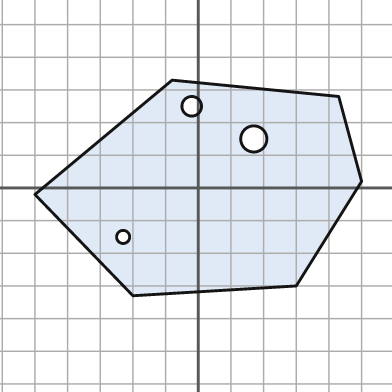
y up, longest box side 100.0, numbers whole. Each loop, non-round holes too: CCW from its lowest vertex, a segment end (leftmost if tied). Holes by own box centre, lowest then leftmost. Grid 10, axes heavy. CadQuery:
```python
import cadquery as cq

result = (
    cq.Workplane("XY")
    .moveTo(-20.0, -33.0)
    .lineTo(30.0, -30.0)
    .lineTo(50.0, 2.0)
    .lineTo(43.0, 28.0)
    .lineTo(-8.0, 33.0)
    .lineTo(-50.0, -2.0)
    .close()
    .moveTo(-23.0, -15.0)
    .circle(2.0)
    .moveTo(17.0, 15.0)
    .circle(4.0)
    .moveTo(-2.0, 25.0)
    .circle(3.0)
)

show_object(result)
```